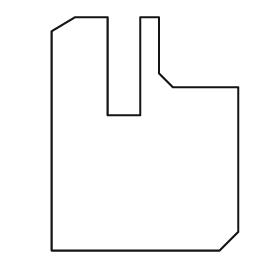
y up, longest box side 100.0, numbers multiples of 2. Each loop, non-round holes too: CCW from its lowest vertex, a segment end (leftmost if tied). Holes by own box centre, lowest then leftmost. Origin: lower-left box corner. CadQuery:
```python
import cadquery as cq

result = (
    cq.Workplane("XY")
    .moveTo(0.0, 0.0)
    .lineTo(72.0, 0.0)
    .lineTo(80.0, 8.0)
    .lineTo(80.0, 70.0)
    .lineTo(52.0, 70.0)
    .lineTo(46.0, 76.0)
    .lineTo(46.0, 100.0)
    .lineTo(38.0, 100.0)
    .lineTo(38.0, 58.0)
    .lineTo(24.0, 58.0)
    .lineTo(24.0, 100.0)
    .lineTo(10.0, 100.0)
    .lineTo(0.0, 94.0)
    .close()
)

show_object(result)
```